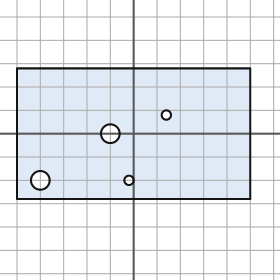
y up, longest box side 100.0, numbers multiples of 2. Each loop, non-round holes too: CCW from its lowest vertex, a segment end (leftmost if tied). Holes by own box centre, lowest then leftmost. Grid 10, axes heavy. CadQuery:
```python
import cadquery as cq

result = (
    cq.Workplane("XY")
    .moveTo(-50.0, -28.0)
    .lineTo(50.0, -28.0)
    .lineTo(50.0, 28.0)
    .lineTo(-50.0, 28.0)
    .close()
    .moveTo(-40.0, -20.0)
    .circle(4.0)
    .moveTo(-2.0, -20.0)
    .circle(2.0)
    .moveTo(-10.0, 0.0)
    .circle(4.0)
    .moveTo(14.0, 8.0)
    .circle(2.0)
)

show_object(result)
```